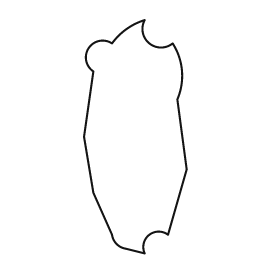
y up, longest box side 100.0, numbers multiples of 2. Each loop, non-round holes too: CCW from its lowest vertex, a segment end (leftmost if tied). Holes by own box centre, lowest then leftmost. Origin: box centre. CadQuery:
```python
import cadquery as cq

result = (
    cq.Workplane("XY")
    .moveTo(4.0, -50.0)
    .threePointArc((6.0, -42.0), (14.0, -42.0))
    .lineTo(22.0, -14.0)
    .lineTo(18.0, 16.0)
    .threePointArc((20.0, 28.0), (16.0, 40.0))
    .threePointArc((6.0, 40.0), (4.0, 50.0))
    .threePointArc((-4.0, 46.0), (-10.0, 40.0))
    .threePointArc((-20.0, 38.0), (-18.0, 28.0))
    .lineTo(-22.0, 0.0)
    .lineTo(-18.0, -24.0)
    .lineTo(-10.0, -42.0)
    .threePointArc((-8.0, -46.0), (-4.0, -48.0))
    .close()
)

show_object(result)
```